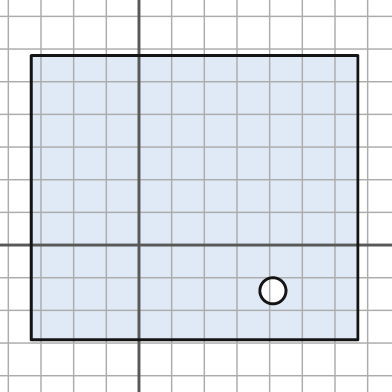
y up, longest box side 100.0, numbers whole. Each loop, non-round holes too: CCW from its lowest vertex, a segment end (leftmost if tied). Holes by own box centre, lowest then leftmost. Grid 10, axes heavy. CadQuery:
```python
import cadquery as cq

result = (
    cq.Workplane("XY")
    .moveTo(-33.0, -29.0)
    .lineTo(67.0, -29.0)
    .lineTo(67.0, 58.0)
    .lineTo(-33.0, 58.0)
    .close()
    .moveTo(41.0, -14.0)
    .circle(4.0)
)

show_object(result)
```